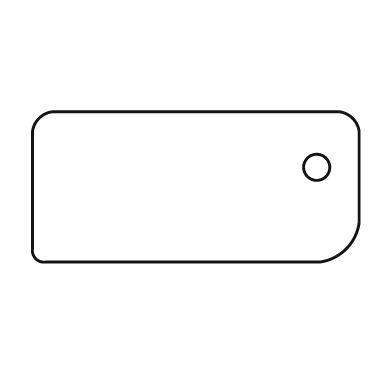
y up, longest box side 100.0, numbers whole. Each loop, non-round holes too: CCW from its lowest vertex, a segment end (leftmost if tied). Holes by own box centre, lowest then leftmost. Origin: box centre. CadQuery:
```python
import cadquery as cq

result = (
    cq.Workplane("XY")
    .moveTo(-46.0, -23.0)
    .lineTo(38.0, -23.0)
    .threePointArc((46.0, -19.0), (50.0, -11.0))
    .lineTo(50.0, 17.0)
    .threePointArc((48.0, 21.0), (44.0, 23.0))
    .lineTo(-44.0, 23.0)
    .threePointArc((-48.0, 21.0), (-50.0, 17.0))
    .lineTo(-50.0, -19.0)
    .threePointArc((-49.0, -22.0), (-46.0, -23.0))
    .close()
    .moveTo(37.0, 6.0)
    .circle(4.0)
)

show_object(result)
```